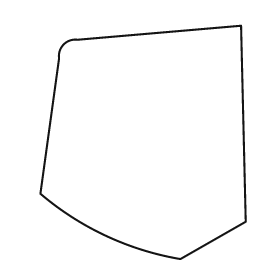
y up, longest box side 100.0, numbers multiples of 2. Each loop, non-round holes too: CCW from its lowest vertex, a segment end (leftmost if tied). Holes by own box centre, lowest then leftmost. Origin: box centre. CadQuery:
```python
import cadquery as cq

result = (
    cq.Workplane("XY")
    .moveTo(16.0, -50.0)
    .lineTo(44.0, -34.0)
    .lineTo(42.0, 50.0)
    .lineTo(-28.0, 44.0)
    .threePointArc((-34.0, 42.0), (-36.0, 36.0))
    .lineTo(-44.0, -22.0)
    .threePointArc((-16.0, -40.0), (16.0, -50.0))
    .close()
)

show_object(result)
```